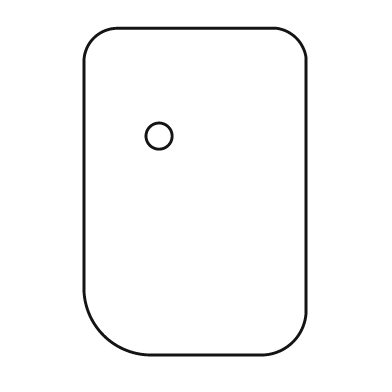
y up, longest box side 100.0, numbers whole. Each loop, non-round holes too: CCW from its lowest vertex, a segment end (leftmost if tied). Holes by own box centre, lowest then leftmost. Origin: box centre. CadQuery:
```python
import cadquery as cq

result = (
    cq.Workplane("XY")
    .moveTo(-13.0, -50.0)
    .lineTo(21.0, -50.0)
    .threePointArc((30.0, -46.0), (34.0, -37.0))
    .lineTo(34.0, 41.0)
    .threePointArc((31.0, 47.0), (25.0, 50.0))
    .lineTo(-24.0, 50.0)
    .threePointArc((-31.0, 47.0), (-34.0, 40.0))
    .lineTo(-34.0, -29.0)
    .threePointArc((-28.0, -44.0), (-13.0, -50.0))
    .close()
    .moveTo(-11.0, 17.0)
    .circle(4.0)
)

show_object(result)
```